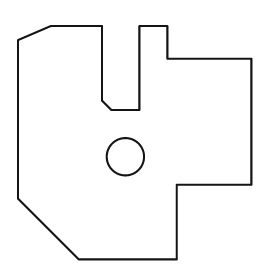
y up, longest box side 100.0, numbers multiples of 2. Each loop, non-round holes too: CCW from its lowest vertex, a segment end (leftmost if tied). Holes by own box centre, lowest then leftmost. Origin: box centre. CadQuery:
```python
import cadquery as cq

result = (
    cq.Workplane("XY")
    .moveTo(-24.0, -50.0)
    .lineTo(18.0, -50.0)
    .lineTo(18.0, -18.0)
    .lineTo(50.0, -18.0)
    .lineTo(50.0, 36.0)
    .lineTo(14.0, 36.0)
    .lineTo(14.0, 50.0)
    .lineTo(2.0, 50.0)
    .lineTo(2.0, 14.0)
    .lineTo(-10.0, 14.0)
    .lineTo(-14.0, 18.0)
    .lineTo(-14.0, 50.0)
    .lineTo(-36.0, 50.0)
    .lineTo(-50.0, 44.0)
    .lineTo(-50.0, -24.0)
    .close()
    .moveTo(-4.0, -6.0)
    .circle(8.0)
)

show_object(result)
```